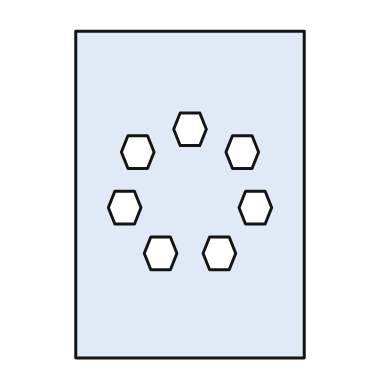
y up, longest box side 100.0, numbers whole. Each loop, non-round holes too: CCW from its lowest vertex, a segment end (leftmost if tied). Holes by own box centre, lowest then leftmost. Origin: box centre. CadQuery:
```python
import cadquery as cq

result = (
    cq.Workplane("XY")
    .moveTo(-35.0, -50.0)
    .lineTo(35.0, -50.0)
    .lineTo(35.0, 50.0)
    .lineTo(-35.0, 50.0)
    .close()
    .moveTo(-12.0, -23.0)
    .lineTo(-6.0, -23.0)
    .lineTo(-4.0, -18.0)
    .lineTo(-6.0, -13.0)
    .lineTo(-12.0, -13.0)
    .lineTo(-14.0, -18.0)
    .close()
    .moveTo(6.0, -23.0)
    .lineTo(12.0, -23.0)
    .lineTo(14.0, -18.0)
    .lineTo(12.0, -13.0)
    .lineTo(6.0, -13.0)
    .lineTo(4.0, -18.0)
    .close()
    .moveTo(-23.0, -9.0)
    .lineTo(-17.0, -9.0)
    .lineTo(-15.0, -4.0)
    .lineTo(-17.0, 1.0)
    .lineTo(-23.0, 1.0)
    .lineTo(-25.0, -4.0)
    .close()
    .moveTo(17.0, -9.0)
    .lineTo(23.0, -9.0)
    .lineTo(25.0, -4.0)
    .lineTo(23.0, 1.0)
    .lineTo(17.0, 1.0)
    .lineTo(15.0, -4.0)
    .close()
    .moveTo(-19.0, 8.0)
    .lineTo(-13.0, 8.0)
    .lineTo(-11.0, 13.0)
    .lineTo(-13.0, 18.0)
    .lineTo(-19.0, 18.0)
    .lineTo(-21.0, 13.0)
    .close()
    .moveTo(13.0, 8.0)
    .lineTo(19.0, 8.0)
    .lineTo(21.0, 13.0)
    .lineTo(19.0, 18.0)
    .lineTo(13.0, 18.0)
    .lineTo(11.0, 13.0)
    .close()
    .moveTo(-3.0, 15.0)
    .lineTo(3.0, 15.0)
    .lineTo(5.0, 20.0)
    .lineTo(3.0, 25.0)
    .lineTo(-3.0, 25.0)
    .lineTo(-5.0, 20.0)
    .close()
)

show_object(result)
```